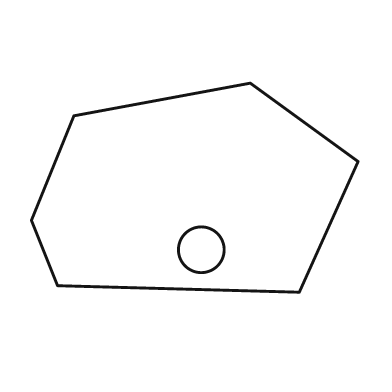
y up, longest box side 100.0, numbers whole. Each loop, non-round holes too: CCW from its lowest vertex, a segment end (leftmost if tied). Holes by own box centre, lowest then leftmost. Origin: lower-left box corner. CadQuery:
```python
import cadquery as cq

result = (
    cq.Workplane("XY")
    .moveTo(82.0, 0.0)
    .lineTo(100.0, 40.0)
    .lineTo(67.0, 64.0)
    .lineTo(13.0, 54.0)
    .lineTo(0.0, 22.0)
    .lineTo(8.0, 2.0)
    .close()
    .moveTo(52.0, 13.0)
    .circle(7.0)
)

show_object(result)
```